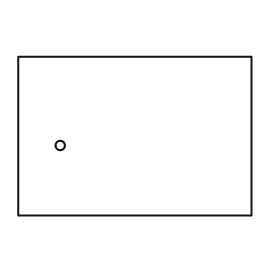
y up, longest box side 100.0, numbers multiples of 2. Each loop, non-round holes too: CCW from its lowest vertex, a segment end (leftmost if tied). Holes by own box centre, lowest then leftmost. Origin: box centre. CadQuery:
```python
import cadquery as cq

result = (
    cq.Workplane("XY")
    .moveTo(-50.0, -34.0)
    .lineTo(50.0, -34.0)
    .lineTo(50.0, 34.0)
    .lineTo(-50.0, 34.0)
    .close()
    .moveTo(-32.0, -4.0)
    .circle(2.0)
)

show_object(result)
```